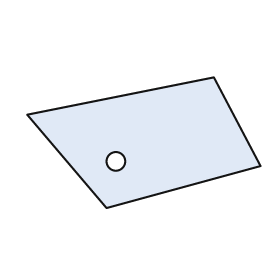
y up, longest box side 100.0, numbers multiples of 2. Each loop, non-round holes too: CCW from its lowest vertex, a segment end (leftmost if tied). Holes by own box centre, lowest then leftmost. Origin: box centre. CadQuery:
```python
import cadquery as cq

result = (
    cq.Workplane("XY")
    .moveTo(-16.0, -28.0)
    .lineTo(50.0, -10.0)
    .lineTo(30.0, 28.0)
    .lineTo(-50.0, 12.0)
    .close()
    .moveTo(-12.0, -8.0)
    .circle(4.0)
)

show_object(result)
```